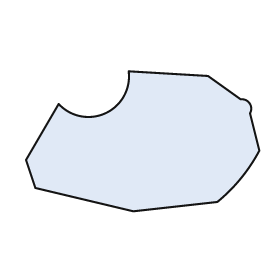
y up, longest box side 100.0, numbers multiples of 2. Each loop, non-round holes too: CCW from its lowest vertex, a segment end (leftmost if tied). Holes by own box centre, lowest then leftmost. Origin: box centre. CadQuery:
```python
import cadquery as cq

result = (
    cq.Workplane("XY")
    .moveTo(-4.0, -30.0)
    .lineTo(32.0, -26.0)
    .threePointArc((42.0, -16.0), (50.0, -4.0))
    .lineTo(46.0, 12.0)
    .threePointArc((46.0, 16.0), (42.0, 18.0))
    .lineTo(28.0, 28.0)
    .lineTo(-6.0, 30.0)
    .threePointArc((-16.0, 12.0), (-36.0, 16.0))
    .lineTo(-50.0, -8.0)
    .lineTo(-46.0, -20.0)
    .close()
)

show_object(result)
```